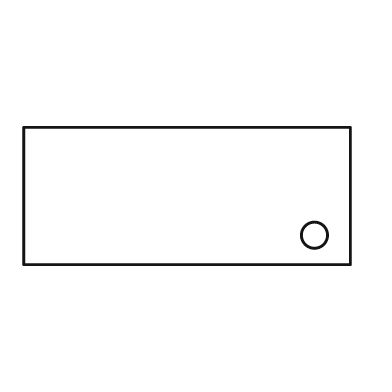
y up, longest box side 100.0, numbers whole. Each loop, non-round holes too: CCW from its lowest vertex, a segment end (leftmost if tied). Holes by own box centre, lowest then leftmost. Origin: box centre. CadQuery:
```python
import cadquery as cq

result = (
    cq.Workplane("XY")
    .moveTo(-50.0, -21.0)
    .lineTo(50.0, -21.0)
    .lineTo(50.0, 21.0)
    .lineTo(-50.0, 21.0)
    .close()
    .moveTo(39.0, -12.0)
    .circle(4.0)
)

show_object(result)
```